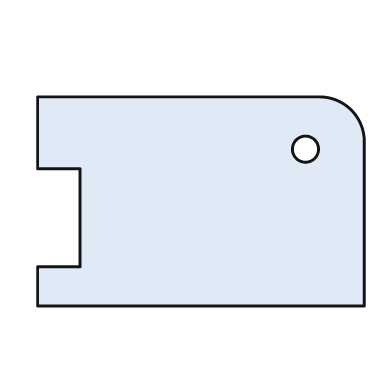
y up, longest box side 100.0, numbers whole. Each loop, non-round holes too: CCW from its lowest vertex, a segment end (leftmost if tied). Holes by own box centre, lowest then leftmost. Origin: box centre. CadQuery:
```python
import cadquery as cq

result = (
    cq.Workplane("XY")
    .moveTo(-50.0, -32.0)
    .lineTo(50.0, -32.0)
    .lineTo(50.0, 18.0)
    .threePointArc((46.0, 28.0), (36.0, 32.0))
    .lineTo(-50.0, 32.0)
    .lineTo(-50.0, 10.0)
    .lineTo(-37.0, 10.0)
    .lineTo(-37.0, -20.0)
    .lineTo(-50.0, -20.0)
    .close()
    .moveTo(32.0, 16.0)
    .circle(4.0)
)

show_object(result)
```